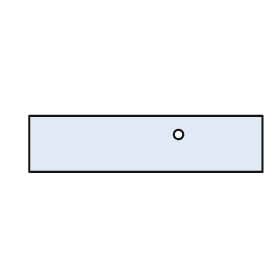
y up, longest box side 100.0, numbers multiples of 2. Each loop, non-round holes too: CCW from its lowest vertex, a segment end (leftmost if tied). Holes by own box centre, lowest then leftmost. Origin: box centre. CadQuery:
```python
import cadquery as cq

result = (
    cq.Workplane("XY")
    .moveTo(-50.0, -12.0)
    .lineTo(50.0, -12.0)
    .lineTo(50.0, 12.0)
    .lineTo(-50.0, 12.0)
    .close()
    .moveTo(14.0, 4.0)
    .circle(2.0)
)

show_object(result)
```